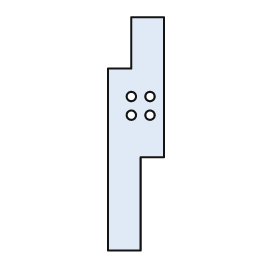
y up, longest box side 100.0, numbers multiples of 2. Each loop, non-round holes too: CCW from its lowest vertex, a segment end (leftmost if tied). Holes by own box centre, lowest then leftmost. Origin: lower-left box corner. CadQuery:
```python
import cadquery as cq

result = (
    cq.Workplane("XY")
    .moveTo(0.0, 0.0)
    .lineTo(14.0, 0.0)
    .lineTo(14.0, 40.0)
    .lineTo(24.0, 40.0)
    .lineTo(24.0, 100.0)
    .lineTo(10.0, 100.0)
    .lineTo(10.0, 78.0)
    .lineTo(0.0, 78.0)
    .close()
    .moveTo(10.0, 58.0)
    .circle(2.0)
    .moveTo(18.0, 58.0)
    .circle(2.0)
    .moveTo(10.0, 66.0)
    .circle(2.0)
    .moveTo(18.0, 66.0)
    .circle(2.0)
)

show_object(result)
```